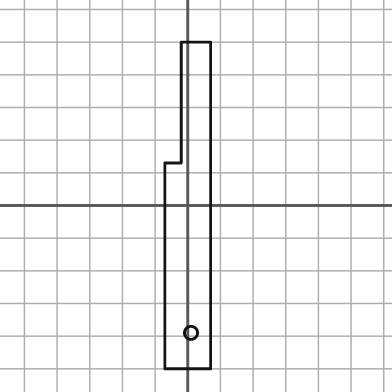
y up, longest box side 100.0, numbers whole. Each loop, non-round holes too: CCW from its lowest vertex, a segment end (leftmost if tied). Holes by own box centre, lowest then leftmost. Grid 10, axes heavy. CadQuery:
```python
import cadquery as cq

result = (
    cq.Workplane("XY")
    .moveTo(-7.0, -50.0)
    .lineTo(7.0, -50.0)
    .lineTo(7.0, 50.0)
    .lineTo(-2.0, 50.0)
    .lineTo(-2.0, 13.0)
    .lineTo(-7.0, 13.0)
    .close()
    .moveTo(1.0, -39.0)
    .circle(2.0)
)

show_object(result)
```